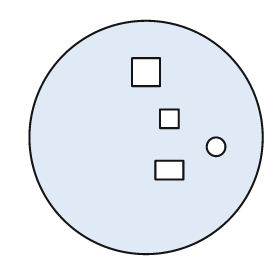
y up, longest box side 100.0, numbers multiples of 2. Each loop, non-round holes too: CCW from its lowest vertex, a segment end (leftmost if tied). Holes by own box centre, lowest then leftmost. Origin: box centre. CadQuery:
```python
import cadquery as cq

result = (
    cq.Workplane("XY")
    .moveTo(0.0, 0.0)
    .circle(50.0)
    .moveTo(4.0, -18.0)
    .lineTo(16.0, -18.0)
    .lineTo(16.0, -10.0)
    .lineTo(4.0, -10.0)
    .close()
    .moveTo(30.0, -4.0)
    .circle(4.0)
    .moveTo(6.0, 4.0)
    .lineTo(14.0, 4.0)
    .lineTo(14.0, 12.0)
    .lineTo(6.0, 12.0)
    .close()
    .moveTo(-6.0, 22.0)
    .lineTo(6.0, 22.0)
    .lineTo(6.0, 34.0)
    .lineTo(-6.0, 34.0)
    .close()
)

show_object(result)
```